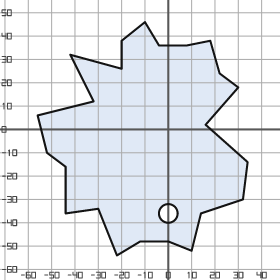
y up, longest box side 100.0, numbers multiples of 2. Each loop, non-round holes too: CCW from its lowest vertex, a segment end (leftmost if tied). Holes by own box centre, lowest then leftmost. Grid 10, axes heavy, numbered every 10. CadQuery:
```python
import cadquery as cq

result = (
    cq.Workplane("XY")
    .moveTo(-22.0, -54.0)
    .lineTo(-12.0, -48.0)
    .lineTo(0.0, -48.0)
    .lineTo(10.0, -52.0)
    .lineTo(14.0, -36.0)
    .lineTo(32.0, -30.0)
    .lineTo(34.0, -14.0)
    .lineTo(16.0, 2.0)
    .lineTo(30.0, 18.0)
    .lineTo(22.0, 24.0)
    .lineTo(18.0, 38.0)
    .lineTo(8.0, 36.0)
    .lineTo(-4.0, 36.0)
    .lineTo(-10.0, 46.0)
    .lineTo(-20.0, 38.0)
    .lineTo(-20.0, 26.0)
    .lineTo(-42.0, 32.0)
    .lineTo(-32.0, 12.0)
    .lineTo(-56.0, 6.0)
    .lineTo(-52.0, -10.0)
    .lineTo(-44.0, -16.0)
    .lineTo(-44.0, -36.0)
    .lineTo(-30.0, -34.0)
    .close()
    .moveTo(0.0, -36.0)
    .circle(4.0)
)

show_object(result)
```